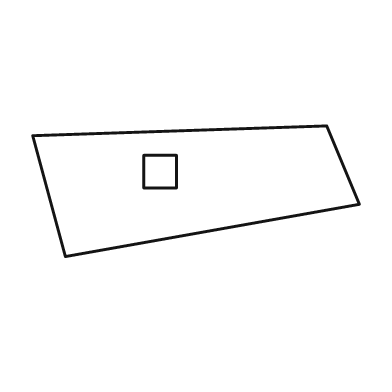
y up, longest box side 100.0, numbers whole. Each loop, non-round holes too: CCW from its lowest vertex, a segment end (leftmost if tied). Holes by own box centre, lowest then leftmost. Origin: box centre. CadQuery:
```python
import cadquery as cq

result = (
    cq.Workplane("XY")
    .moveTo(-40.0, -20.0)
    .lineTo(50.0, -4.0)
    .lineTo(40.0, 20.0)
    .lineTo(-50.0, 17.0)
    .close()
    .moveTo(-16.0, 1.0)
    .lineTo(-6.0, 1.0)
    .lineTo(-6.0, 11.0)
    .lineTo(-16.0, 11.0)
    .close()
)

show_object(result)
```